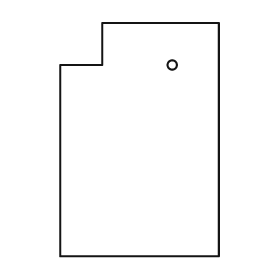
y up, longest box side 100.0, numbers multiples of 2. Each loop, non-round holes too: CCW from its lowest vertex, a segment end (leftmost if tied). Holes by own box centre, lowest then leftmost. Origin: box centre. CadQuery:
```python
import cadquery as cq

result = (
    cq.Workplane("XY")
    .moveTo(-34.0, -50.0)
    .lineTo(34.0, -50.0)
    .lineTo(34.0, 50.0)
    .lineTo(-16.0, 50.0)
    .lineTo(-16.0, 32.0)
    .lineTo(-34.0, 32.0)
    .close()
    .moveTo(14.0, 32.0)
    .circle(2.0)
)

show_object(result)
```